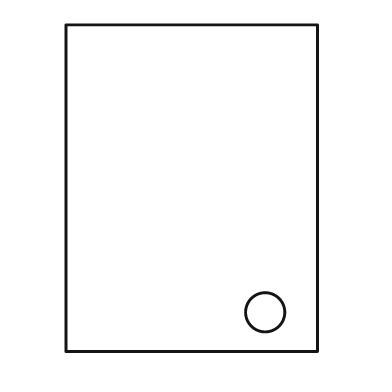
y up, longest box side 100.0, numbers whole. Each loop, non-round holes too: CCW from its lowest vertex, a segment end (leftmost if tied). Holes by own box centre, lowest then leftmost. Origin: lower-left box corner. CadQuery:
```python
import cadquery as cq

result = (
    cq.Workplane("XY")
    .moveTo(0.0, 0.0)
    .lineTo(77.0, 0.0)
    .lineTo(77.0, 100.0)
    .lineTo(0.0, 100.0)
    .close()
    .moveTo(61.0, 12.0)
    .circle(6.0)
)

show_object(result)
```